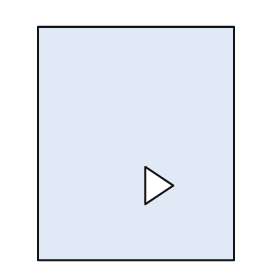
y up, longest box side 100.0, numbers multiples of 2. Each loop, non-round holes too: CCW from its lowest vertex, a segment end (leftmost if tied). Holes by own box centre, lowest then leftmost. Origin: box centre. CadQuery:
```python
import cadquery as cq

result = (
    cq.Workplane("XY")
    .moveTo(-42.0, -50.0)
    .lineTo(42.0, -50.0)
    .lineTo(42.0, 50.0)
    .lineTo(-42.0, 50.0)
    .close()
    .moveTo(4.0, -26.0)
    .lineTo(16.0, -18.0)
    .lineTo(4.0, -10.0)
    .close()
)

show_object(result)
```